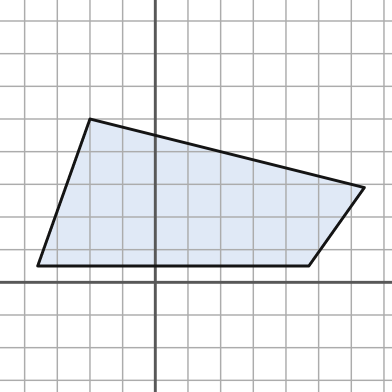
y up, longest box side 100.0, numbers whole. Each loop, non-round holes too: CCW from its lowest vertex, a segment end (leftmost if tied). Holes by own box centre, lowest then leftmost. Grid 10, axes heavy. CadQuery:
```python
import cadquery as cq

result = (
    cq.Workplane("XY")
    .moveTo(-36.0, 5.0)
    .lineTo(47.0, 5.0)
    .lineTo(64.0, 29.0)
    .lineTo(-20.0, 50.0)
    .close()
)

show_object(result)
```